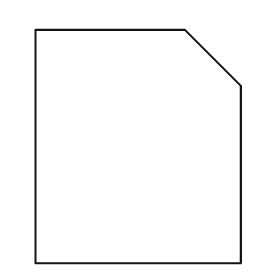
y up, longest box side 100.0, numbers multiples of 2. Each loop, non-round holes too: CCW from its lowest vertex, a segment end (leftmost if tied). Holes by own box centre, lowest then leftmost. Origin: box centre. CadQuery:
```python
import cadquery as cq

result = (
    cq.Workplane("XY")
    .moveTo(-44.0, -50.0)
    .lineTo(44.0, -50.0)
    .lineTo(44.0, 26.0)
    .lineTo(20.0, 50.0)
    .lineTo(-44.0, 50.0)
    .close()
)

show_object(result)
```